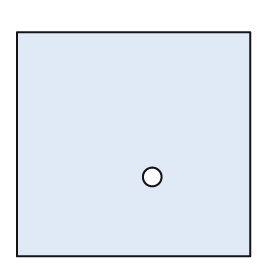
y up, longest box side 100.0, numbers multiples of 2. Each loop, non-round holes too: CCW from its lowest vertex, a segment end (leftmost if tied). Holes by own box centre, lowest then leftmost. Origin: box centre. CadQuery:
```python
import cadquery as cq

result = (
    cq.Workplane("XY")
    .moveTo(-50.0, -48.0)
    .lineTo(50.0, -48.0)
    .lineTo(50.0, 48.0)
    .lineTo(-50.0, 48.0)
    .close()
    .moveTo(8.0, -14.0)
    .circle(4.0)
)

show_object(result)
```